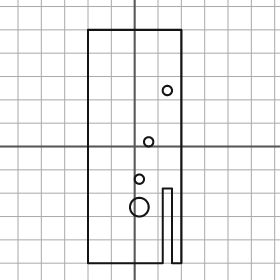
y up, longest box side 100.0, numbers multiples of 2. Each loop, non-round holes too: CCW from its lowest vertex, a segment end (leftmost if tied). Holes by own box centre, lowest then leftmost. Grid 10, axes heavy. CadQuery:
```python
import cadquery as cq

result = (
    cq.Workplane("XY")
    .moveTo(-20.0, -50.0)
    .lineTo(12.0, -50.0)
    .lineTo(12.0, -18.0)
    .lineTo(16.0, -18.0)
    .lineTo(16.0, -50.0)
    .lineTo(20.0, -50.0)
    .lineTo(20.0, 50.0)
    .lineTo(-20.0, 50.0)
    .close()
    .moveTo(2.0, -26.0)
    .circle(4.0)
    .moveTo(2.0, -14.0)
    .circle(2.0)
    .moveTo(6.0, 2.0)
    .circle(2.0)
    .moveTo(14.0, 24.0)
    .circle(2.0)
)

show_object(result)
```